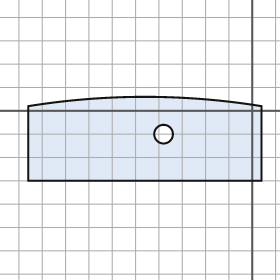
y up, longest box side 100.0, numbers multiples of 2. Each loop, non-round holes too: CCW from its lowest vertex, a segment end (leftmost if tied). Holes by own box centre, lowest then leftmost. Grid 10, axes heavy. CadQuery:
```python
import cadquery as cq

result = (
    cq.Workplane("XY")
    .moveTo(-96.0, -30.0)
    .lineTo(4.0, -30.0)
    .lineTo(4.0, 2.0)
    .threePointArc((-46.0, 6.0), (-96.0, 2.0))
    .close()
    .moveTo(-38.0, -10.0)
    .circle(4.0)
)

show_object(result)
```